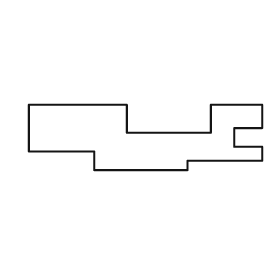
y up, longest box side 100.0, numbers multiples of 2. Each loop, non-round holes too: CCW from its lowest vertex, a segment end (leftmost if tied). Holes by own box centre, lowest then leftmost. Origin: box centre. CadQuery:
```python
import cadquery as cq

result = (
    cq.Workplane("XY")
    .moveTo(-22.0, -14.0)
    .lineTo(18.0, -14.0)
    .lineTo(18.0, -10.0)
    .lineTo(50.0, -10.0)
    .lineTo(50.0, -4.0)
    .lineTo(38.0, -4.0)
    .lineTo(38.0, 4.0)
    .lineTo(50.0, 4.0)
    .lineTo(50.0, 14.0)
    .lineTo(28.0, 14.0)
    .lineTo(28.0, 2.0)
    .lineTo(-8.0, 2.0)
    .lineTo(-8.0, 14.0)
    .lineTo(-50.0, 14.0)
    .lineTo(-50.0, -6.0)
    .lineTo(-22.0, -6.0)
    .close()
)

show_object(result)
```